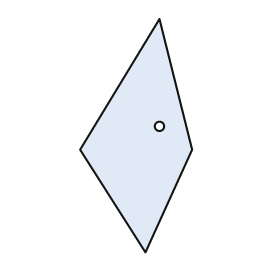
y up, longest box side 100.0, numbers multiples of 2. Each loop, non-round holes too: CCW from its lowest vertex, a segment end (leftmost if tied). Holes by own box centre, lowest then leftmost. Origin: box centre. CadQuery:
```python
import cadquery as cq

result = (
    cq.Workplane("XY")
    .moveTo(4.0, -50.0)
    .lineTo(24.0, -6.0)
    .lineTo(10.0, 50.0)
    .lineTo(-24.0, -6.0)
    .close()
    .moveTo(10.0, 4.0)
    .circle(2.0)
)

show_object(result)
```